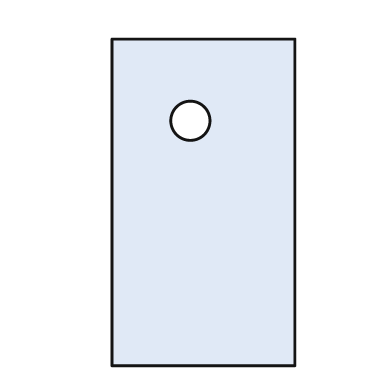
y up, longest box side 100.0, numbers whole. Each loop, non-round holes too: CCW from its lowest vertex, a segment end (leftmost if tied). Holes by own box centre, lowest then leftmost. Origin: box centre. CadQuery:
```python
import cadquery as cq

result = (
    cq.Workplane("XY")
    .moveTo(-28.0, -50.0)
    .lineTo(28.0, -50.0)
    .lineTo(28.0, 50.0)
    .lineTo(-28.0, 50.0)
    .close()
    .moveTo(-4.0, 25.0)
    .circle(6.0)
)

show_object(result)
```